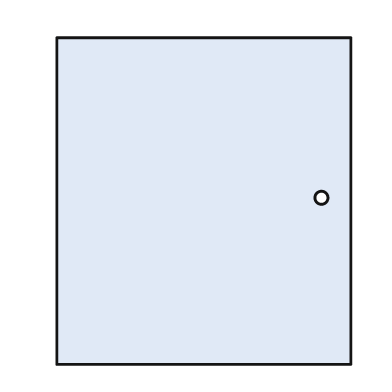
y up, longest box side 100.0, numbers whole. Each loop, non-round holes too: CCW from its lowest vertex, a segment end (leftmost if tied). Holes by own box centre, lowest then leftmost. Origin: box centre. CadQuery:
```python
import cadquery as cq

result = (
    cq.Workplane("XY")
    .moveTo(-45.0, -50.0)
    .lineTo(45.0, -50.0)
    .lineTo(45.0, 50.0)
    .lineTo(-45.0, 50.0)
    .close()
    .moveTo(36.0, 1.0)
    .circle(2.0)
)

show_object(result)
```